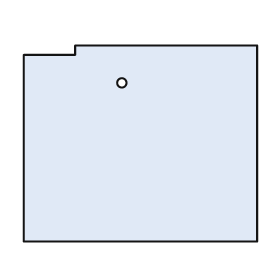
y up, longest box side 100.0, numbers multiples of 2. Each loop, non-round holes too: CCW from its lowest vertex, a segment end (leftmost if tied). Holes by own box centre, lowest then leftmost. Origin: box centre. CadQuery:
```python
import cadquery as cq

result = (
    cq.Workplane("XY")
    .moveTo(-50.0, -42.0)
    .lineTo(50.0, -42.0)
    .lineTo(50.0, 42.0)
    .lineTo(-28.0, 42.0)
    .lineTo(-28.0, 38.0)
    .lineTo(-50.0, 38.0)
    .close()
    .moveTo(-8.0, 26.0)
    .circle(2.0)
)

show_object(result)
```